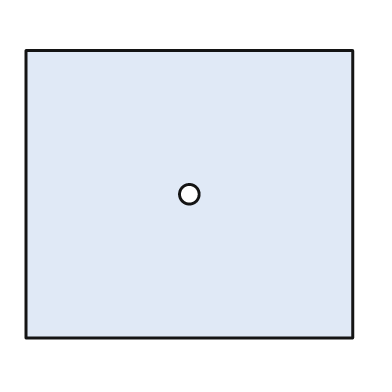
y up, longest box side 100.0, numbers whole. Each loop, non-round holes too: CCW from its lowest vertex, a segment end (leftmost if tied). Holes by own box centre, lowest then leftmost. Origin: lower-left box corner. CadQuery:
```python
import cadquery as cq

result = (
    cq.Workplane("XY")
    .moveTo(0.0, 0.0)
    .lineTo(100.0, 0.0)
    .lineTo(100.0, 88.0)
    .lineTo(0.0, 88.0)
    .close()
    .moveTo(50.0, 44.0)
    .circle(3.0)
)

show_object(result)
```